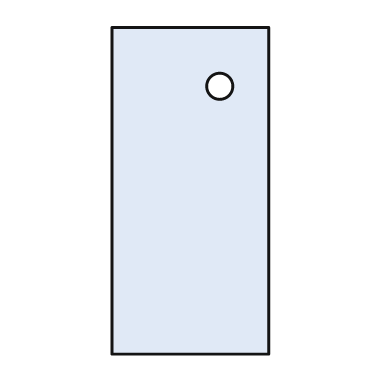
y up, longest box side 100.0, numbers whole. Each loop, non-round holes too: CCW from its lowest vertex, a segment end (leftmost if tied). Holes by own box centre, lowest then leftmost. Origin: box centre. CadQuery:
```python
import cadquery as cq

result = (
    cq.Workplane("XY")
    .moveTo(-24.0, -50.0)
    .lineTo(24.0, -50.0)
    .lineTo(24.0, 50.0)
    .lineTo(-24.0, 50.0)
    .close()
    .moveTo(9.0, 32.0)
    .circle(4.0)
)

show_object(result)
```